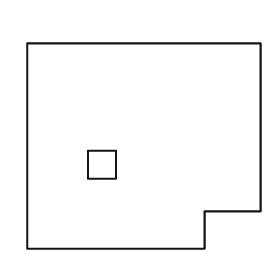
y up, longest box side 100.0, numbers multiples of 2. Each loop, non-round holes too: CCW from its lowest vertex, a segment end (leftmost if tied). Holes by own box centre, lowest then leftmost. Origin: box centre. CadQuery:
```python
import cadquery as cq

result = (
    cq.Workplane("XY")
    .moveTo(-50.0, -44.0)
    .lineTo(26.0, -44.0)
    .lineTo(26.0, -28.0)
    .lineTo(50.0, -28.0)
    .lineTo(50.0, 44.0)
    .lineTo(-50.0, 44.0)
    .close()
    .moveTo(-24.0, -14.0)
    .lineTo(-12.0, -14.0)
    .lineTo(-12.0, -2.0)
    .lineTo(-24.0, -2.0)
    .close()
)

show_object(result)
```